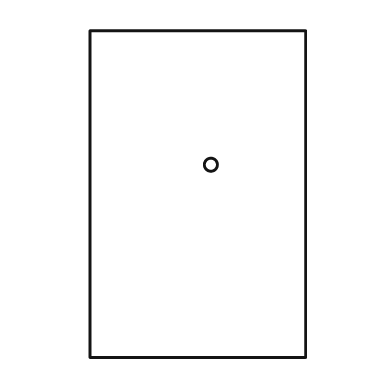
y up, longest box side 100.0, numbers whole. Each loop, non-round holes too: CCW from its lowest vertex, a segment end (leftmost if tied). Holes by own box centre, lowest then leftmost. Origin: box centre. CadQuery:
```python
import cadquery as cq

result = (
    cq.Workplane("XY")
    .moveTo(-33.0, -50.0)
    .lineTo(33.0, -50.0)
    .lineTo(33.0, 50.0)
    .lineTo(-33.0, 50.0)
    .close()
    .moveTo(4.0, 9.0)
    .circle(2.0)
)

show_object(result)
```